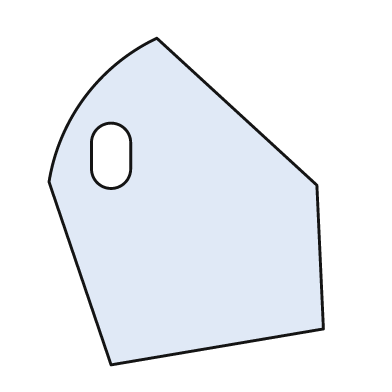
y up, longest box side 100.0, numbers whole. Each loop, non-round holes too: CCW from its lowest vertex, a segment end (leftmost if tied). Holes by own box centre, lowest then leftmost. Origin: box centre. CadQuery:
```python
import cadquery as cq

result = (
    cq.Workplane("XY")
    .moveTo(-23.0, -50.0)
    .lineTo(42.0, -39.0)
    .lineTo(40.0, 5.0)
    .lineTo(-9.0, 50.0)
    .threePointArc((-31.0, 32.0), (-42.0, 6.0))
    .close()
    .moveTo(-29.0, 10.0)
    .threePointArc((-23.0, 4.0), (-17.0, 10.0))
    .lineTo(-17.0, 18.0)
    .threePointArc((-23.0, 24.0), (-29.0, 18.0))
    .close()
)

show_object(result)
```